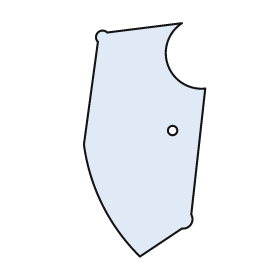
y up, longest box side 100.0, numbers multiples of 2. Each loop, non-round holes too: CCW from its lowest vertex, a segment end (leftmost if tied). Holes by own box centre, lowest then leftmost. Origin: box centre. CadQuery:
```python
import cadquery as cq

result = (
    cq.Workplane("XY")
    .moveTo(-2.0, -50.0)
    .lineTo(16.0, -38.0)
    .threePointArc((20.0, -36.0), (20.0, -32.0))
    .lineTo(26.0, 22.0)
    .threePointArc((10.0, 32.0), (16.0, 50.0))
    .lineTo(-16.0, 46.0)
    .threePointArc((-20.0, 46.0), (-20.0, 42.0))
    .lineTo(-26.0, -2.0)
    .threePointArc((-18.0, -28.0), (-2.0, -50.0))
    .close()
    .moveTo(12.0, 4.0)
    .circle(2.0)
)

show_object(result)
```